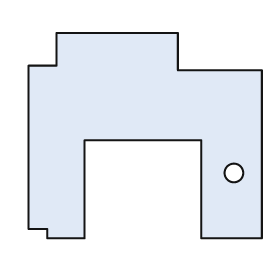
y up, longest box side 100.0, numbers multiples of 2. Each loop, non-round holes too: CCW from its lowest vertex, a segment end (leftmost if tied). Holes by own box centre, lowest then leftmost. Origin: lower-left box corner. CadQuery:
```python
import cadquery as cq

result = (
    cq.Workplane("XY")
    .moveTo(8.0, 0.0)
    .lineTo(24.0, 0.0)
    .lineTo(24.0, 42.0)
    .lineTo(74.0, 42.0)
    .lineTo(74.0, 0.0)
    .lineTo(100.0, 0.0)
    .lineTo(100.0, 72.0)
    .lineTo(64.0, 72.0)
    .lineTo(64.0, 88.0)
    .lineTo(12.0, 88.0)
    .lineTo(12.0, 74.0)
    .lineTo(0.0, 74.0)
    .lineTo(0.0, 4.0)
    .lineTo(8.0, 4.0)
    .close()
    .moveTo(88.0, 28.0)
    .circle(4.0)
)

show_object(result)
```